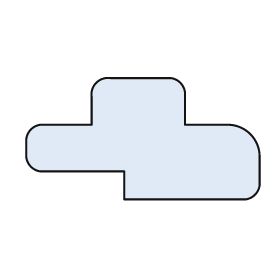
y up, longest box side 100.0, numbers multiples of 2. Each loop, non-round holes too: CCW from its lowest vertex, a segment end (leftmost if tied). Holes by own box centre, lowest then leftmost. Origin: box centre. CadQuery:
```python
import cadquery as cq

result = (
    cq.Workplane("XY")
    .moveTo(-8.0, -26.0)
    .lineTo(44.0, -26.0)
    .threePointArc((48.0, -24.0), (50.0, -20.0))
    .lineTo(50.0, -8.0)
    .threePointArc((46.0, 2.0), (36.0, 6.0))
    .lineTo(18.0, 6.0)
    .lineTo(18.0, 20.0)
    .threePointArc((16.0, 24.0), (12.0, 26.0))
    .lineTo(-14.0, 26.0)
    .threePointArc((-20.0, 24.0), (-22.0, 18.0))
    .lineTo(-22.0, 6.0)
    .lineTo(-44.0, 6.0)
    .threePointArc((-48.0, 4.0), (-50.0, 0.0))
    .lineTo(-50.0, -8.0)
    .threePointArc((-48.0, -12.0), (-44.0, -14.0))
    .lineTo(-8.0, -14.0)
    .close()
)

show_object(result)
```